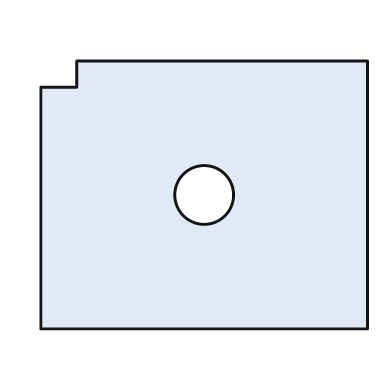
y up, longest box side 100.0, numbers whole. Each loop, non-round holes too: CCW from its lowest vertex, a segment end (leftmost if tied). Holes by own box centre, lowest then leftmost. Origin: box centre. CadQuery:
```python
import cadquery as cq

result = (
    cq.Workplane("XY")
    .moveTo(-50.0, -41.0)
    .lineTo(50.0, -41.0)
    .lineTo(50.0, 41.0)
    .lineTo(-39.0, 41.0)
    .lineTo(-39.0, 33.0)
    .lineTo(-50.0, 33.0)
    .close()
    .moveTo(0.0, 0.0)
    .circle(9.0)
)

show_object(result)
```